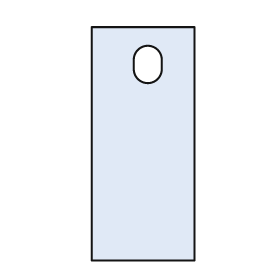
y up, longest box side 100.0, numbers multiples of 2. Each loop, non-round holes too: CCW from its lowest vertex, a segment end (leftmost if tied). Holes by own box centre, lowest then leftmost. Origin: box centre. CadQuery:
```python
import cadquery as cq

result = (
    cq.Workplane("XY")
    .moveTo(-22.0, -50.0)
    .lineTo(22.0, -50.0)
    .lineTo(22.0, 50.0)
    .lineTo(-22.0, 50.0)
    .close()
    .moveTo(-4.0, 32.0)
    .threePointArc((2.0, 26.0), (8.0, 32.0))
    .lineTo(8.0, 36.0)
    .threePointArc((2.0, 42.0), (-4.0, 36.0))
    .close()
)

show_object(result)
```